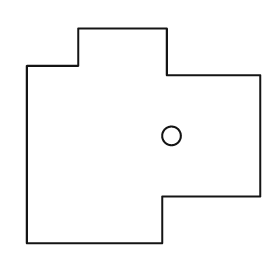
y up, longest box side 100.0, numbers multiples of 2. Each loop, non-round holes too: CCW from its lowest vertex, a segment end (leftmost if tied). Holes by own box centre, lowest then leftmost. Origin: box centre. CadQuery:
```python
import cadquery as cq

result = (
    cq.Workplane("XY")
    .moveTo(-50.0, -46.0)
    .lineTo(8.0, -46.0)
    .lineTo(8.0, -26.0)
    .lineTo(50.0, -26.0)
    .lineTo(50.0, 26.0)
    .lineTo(10.0, 26.0)
    .lineTo(10.0, 46.0)
    .lineTo(-28.0, 46.0)
    .lineTo(-28.0, 30.0)
    .lineTo(-50.0, 30.0)
    .close()
    .moveTo(12.0, 0.0)
    .circle(4.0)
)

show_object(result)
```